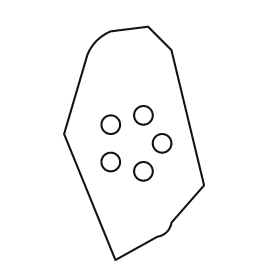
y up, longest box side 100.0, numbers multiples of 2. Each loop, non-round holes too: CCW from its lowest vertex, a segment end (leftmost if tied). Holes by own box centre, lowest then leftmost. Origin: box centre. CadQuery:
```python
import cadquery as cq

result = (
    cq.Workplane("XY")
    .moveTo(-8.0, -50.0)
    .lineTo(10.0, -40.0)
    .threePointArc((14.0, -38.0), (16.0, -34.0))
    .lineTo(30.0, -18.0)
    .lineTo(16.0, 40.0)
    .lineTo(6.0, 50.0)
    .lineTo(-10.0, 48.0)
    .threePointArc((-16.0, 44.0), (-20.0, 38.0))
    .lineTo(-30.0, 4.0)
    .close()
    .moveTo(4.0, -12.0)
    .circle(4.0)
    .moveTo(-10.0, -8.0)
    .circle(4.0)
    .moveTo(12.0, 0.0)
    .circle(4.0)
    .moveTo(-10.0, 8.0)
    .circle(4.0)
    .moveTo(4.0, 12.0)
    .circle(4.0)
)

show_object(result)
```